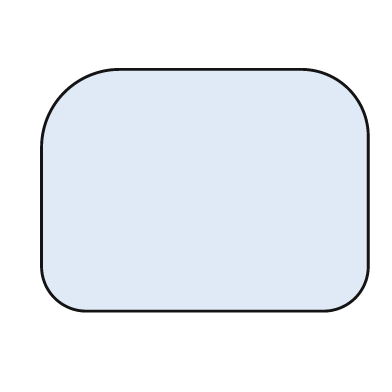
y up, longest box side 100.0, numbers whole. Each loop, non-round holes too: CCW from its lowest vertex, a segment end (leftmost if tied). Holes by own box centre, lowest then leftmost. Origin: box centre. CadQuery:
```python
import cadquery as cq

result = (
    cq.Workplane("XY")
    .moveTo(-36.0, -37.0)
    .lineTo(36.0, -37.0)
    .threePointArc((46.0, -33.0), (50.0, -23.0))
    .lineTo(50.0, 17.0)
    .threePointArc((44.0, 31.0), (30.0, 37.0))
    .lineTo(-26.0, 37.0)
    .threePointArc((-43.0, 30.0), (-50.0, 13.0))
    .lineTo(-50.0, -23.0)
    .threePointArc((-46.0, -33.0), (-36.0, -37.0))
    .close()
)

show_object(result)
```